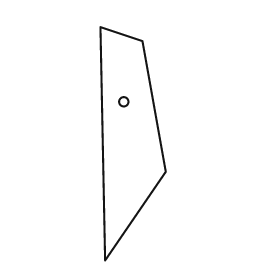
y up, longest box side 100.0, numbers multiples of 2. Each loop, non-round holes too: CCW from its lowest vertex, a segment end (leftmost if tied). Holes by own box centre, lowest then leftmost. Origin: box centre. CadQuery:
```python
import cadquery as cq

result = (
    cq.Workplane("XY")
    .moveTo(-12.0, -50.0)
    .lineTo(14.0, -12.0)
    .lineTo(4.0, 44.0)
    .lineTo(-14.0, 50.0)
    .close()
    .moveTo(-4.0, 18.0)
    .circle(2.0)
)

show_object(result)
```